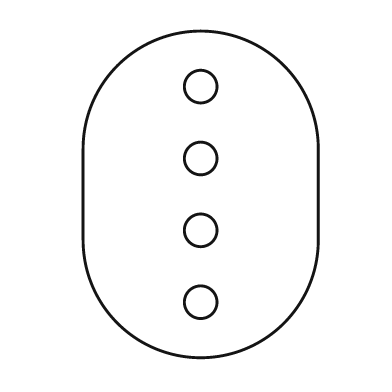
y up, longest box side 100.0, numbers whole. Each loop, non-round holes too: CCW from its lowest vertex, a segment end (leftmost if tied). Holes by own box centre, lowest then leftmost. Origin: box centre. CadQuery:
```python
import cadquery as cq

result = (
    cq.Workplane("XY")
    .moveTo(-36.0, -14.0)
    .threePointArc((0.0, -50.0), (36.0, -14.0))
    .lineTo(36.0, 14.0)
    .threePointArc((0.0, 50.0), (-36.0, 14.0))
    .close()
    .moveTo(0.0, -33.0)
    .circle(5.0)
    .moveTo(0.0, -11.0)
    .circle(5.0)
    .moveTo(0.0, 11.0)
    .circle(5.0)
    .moveTo(0.0, 33.0)
    .circle(5.0)
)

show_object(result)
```